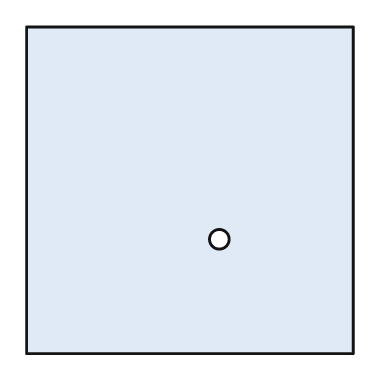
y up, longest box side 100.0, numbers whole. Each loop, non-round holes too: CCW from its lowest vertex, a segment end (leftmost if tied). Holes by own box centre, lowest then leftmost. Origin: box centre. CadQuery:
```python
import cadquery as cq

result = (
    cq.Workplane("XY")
    .moveTo(-50.0, -50.0)
    .lineTo(50.0, -50.0)
    .lineTo(50.0, 50.0)
    .lineTo(-50.0, 50.0)
    .close()
    .moveTo(9.0, -15.0)
    .circle(3.0)
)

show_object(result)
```